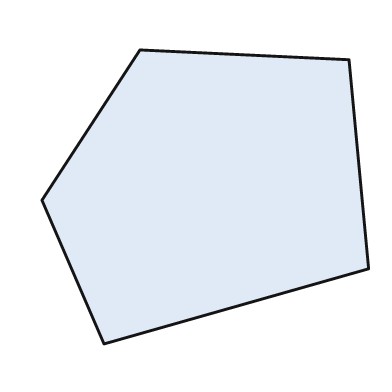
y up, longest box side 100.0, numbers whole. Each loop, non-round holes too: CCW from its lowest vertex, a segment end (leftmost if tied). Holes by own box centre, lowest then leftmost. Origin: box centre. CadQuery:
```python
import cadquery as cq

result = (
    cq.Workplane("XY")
    .moveTo(-31.0, -45.0)
    .lineTo(50.0, -22.0)
    .lineTo(44.0, 42.0)
    .lineTo(-20.0, 45.0)
    .lineTo(-50.0, -1.0)
    .close()
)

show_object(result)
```